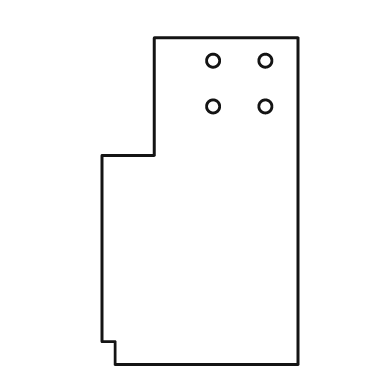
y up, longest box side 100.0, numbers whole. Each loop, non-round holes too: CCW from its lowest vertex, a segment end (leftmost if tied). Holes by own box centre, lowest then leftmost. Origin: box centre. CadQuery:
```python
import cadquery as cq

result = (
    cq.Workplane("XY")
    .moveTo(-26.0, -50.0)
    .lineTo(30.0, -50.0)
    .lineTo(30.0, 50.0)
    .lineTo(-14.0, 50.0)
    .lineTo(-14.0, 14.0)
    .lineTo(-30.0, 14.0)
    .lineTo(-30.0, -43.0)
    .lineTo(-26.0, -43.0)
    .close()
    .moveTo(4.0, 29.0)
    .circle(2.0)
    .moveTo(20.0, 29.0)
    .circle(2.0)
    .moveTo(4.0, 43.0)
    .circle(2.0)
    .moveTo(20.0, 43.0)
    .circle(2.0)
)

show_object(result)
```